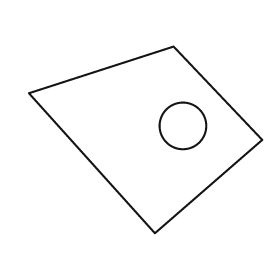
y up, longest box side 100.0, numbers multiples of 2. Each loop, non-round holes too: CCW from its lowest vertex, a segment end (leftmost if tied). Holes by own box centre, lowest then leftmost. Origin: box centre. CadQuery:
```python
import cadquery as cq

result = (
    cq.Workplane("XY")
    .moveTo(4.0, -40.0)
    .lineTo(50.0, 0.0)
    .lineTo(12.0, 40.0)
    .lineTo(-50.0, 20.0)
    .close()
    .moveTo(16.0, 6.0)
    .circle(10.0)
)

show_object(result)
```